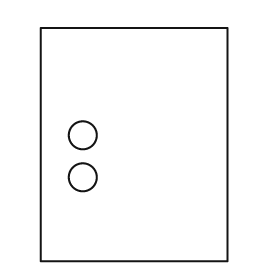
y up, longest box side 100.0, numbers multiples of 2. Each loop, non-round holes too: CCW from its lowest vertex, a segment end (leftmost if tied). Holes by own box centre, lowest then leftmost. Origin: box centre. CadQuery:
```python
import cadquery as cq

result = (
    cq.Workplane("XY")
    .moveTo(-40.0, -50.0)
    .lineTo(40.0, -50.0)
    .lineTo(40.0, 50.0)
    .lineTo(-40.0, 50.0)
    .close()
    .moveTo(-22.0, -14.0)
    .circle(6.0)
    .moveTo(-22.0, 4.0)
    .circle(6.0)
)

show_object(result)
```